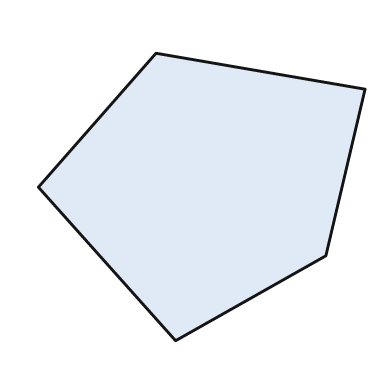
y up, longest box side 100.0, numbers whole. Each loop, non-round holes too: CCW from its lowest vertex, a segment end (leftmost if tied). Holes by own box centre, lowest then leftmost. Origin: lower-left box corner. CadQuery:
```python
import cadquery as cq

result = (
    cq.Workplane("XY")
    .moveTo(42.0, 0.0)
    .lineTo(88.0, 26.0)
    .lineTo(100.0, 77.0)
    .lineTo(36.0, 88.0)
    .lineTo(0.0, 47.0)
    .close()
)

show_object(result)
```